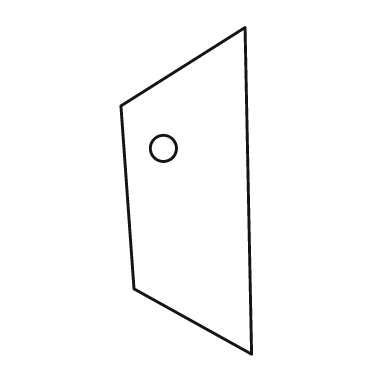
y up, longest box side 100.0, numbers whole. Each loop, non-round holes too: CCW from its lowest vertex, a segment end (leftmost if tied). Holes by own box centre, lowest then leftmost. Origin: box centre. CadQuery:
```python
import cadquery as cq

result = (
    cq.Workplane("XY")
    .moveTo(20.0, -50.0)
    .lineTo(18.0, 50.0)
    .lineTo(-20.0, 26.0)
    .lineTo(-16.0, -30.0)
    .close()
    .moveTo(-7.0, 13.0)
    .circle(4.0)
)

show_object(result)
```